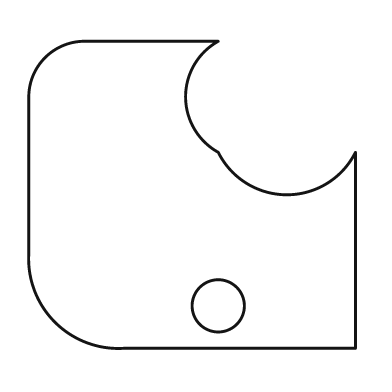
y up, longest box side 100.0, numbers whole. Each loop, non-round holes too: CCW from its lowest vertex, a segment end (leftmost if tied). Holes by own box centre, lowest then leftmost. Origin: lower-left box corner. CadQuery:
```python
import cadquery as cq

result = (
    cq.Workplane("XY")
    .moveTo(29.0, 0.0)
    .lineTo(100.0, 0.0)
    .lineTo(100.0, 60.0)
    .threePointArc((79.0, 47.0), (58.0, 60.0))
    .threePointArc((48.0, 77.0), (58.0, 94.0))
    .lineTo(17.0, 94.0)
    .threePointArc((5.0, 89.0), (0.0, 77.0))
    .lineTo(0.0, 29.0)
    .threePointArc((8.0, 8.0), (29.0, 0.0))
    .close()
    .moveTo(58.0, 13.0)
    .circle(8.0)
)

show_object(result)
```